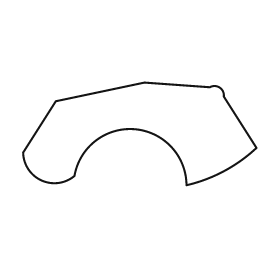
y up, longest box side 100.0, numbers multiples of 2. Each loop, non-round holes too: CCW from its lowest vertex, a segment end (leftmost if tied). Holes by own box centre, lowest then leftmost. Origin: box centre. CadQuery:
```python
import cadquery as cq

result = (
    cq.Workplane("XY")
    .moveTo(20.0, -22.0)
    .threePointArc((36.0, -16.0), (50.0, -6.0))
    .lineTo(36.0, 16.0)
    .threePointArc((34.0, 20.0), (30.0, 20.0))
    .lineTo(2.0, 22.0)
    .lineTo(-36.0, 14.0)
    .lineTo(-50.0, -8.0)
    .threePointArc((-42.0, -20.0), (-28.0, -18.0))
    .threePointArc((-2.0, 2.0), (20.0, -22.0))
    .close()
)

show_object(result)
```